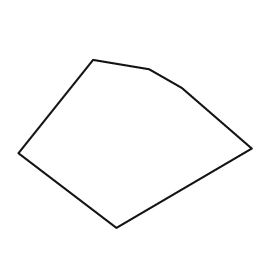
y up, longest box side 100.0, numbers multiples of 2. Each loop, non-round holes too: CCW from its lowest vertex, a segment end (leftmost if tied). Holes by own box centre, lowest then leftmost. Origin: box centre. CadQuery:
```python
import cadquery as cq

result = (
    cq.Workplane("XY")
    .moveTo(-8.0, -36.0)
    .lineTo(50.0, -2.0)
    .lineTo(20.0, 24.0)
    .lineTo(6.0, 32.0)
    .lineTo(-18.0, 36.0)
    .lineTo(-50.0, -4.0)
    .close()
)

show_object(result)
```